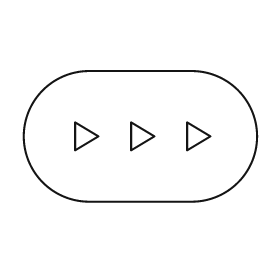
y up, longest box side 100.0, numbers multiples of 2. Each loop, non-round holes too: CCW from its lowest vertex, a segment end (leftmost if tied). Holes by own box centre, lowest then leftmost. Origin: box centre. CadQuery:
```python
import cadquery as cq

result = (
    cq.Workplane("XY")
    .moveTo(-22.0, -28.0)
    .lineTo(22.0, -28.0)
    .threePointArc((50.0, 0.0), (22.0, 28.0))
    .lineTo(-22.0, 28.0)
    .threePointArc((-50.0, 0.0), (-22.0, -28.0))
    .close()
    .moveTo(-28.0, -6.0)
    .lineTo(-18.0, 0.0)
    .lineTo(-28.0, 6.0)
    .close()
    .moveTo(-4.0, -6.0)
    .lineTo(6.0, 0.0)
    .lineTo(-4.0, 6.0)
    .close()
    .moveTo(20.0, -6.0)
    .lineTo(30.0, 0.0)
    .lineTo(20.0, 6.0)
    .close()
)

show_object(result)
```